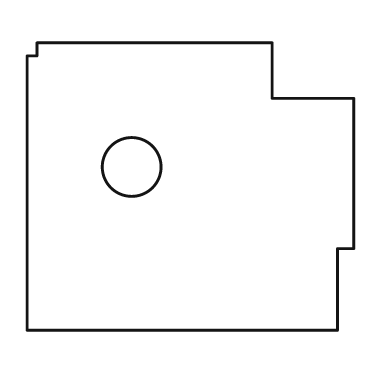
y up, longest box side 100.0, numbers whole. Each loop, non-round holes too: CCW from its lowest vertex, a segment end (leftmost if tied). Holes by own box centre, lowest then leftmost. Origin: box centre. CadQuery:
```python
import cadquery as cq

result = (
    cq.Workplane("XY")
    .moveTo(-50.0, -44.0)
    .lineTo(45.0, -44.0)
    .lineTo(45.0, -19.0)
    .lineTo(50.0, -19.0)
    .lineTo(50.0, 27.0)
    .lineTo(25.0, 27.0)
    .lineTo(25.0, 44.0)
    .lineTo(-47.0, 44.0)
    .lineTo(-47.0, 40.0)
    .lineTo(-50.0, 40.0)
    .close()
    .moveTo(-18.0, 6.0)
    .circle(9.0)
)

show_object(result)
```